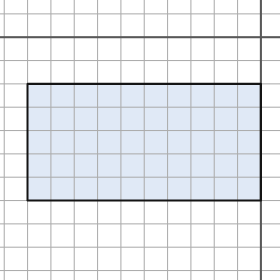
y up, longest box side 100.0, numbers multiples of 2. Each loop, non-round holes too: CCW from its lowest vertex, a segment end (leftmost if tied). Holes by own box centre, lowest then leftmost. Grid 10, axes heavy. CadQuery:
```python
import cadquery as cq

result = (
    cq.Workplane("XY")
    .moveTo(-100.0, -70.0)
    .lineTo(0.0, -70.0)
    .lineTo(0.0, -20.0)
    .lineTo(-100.0, -20.0)
    .close()
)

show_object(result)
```